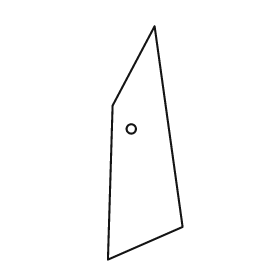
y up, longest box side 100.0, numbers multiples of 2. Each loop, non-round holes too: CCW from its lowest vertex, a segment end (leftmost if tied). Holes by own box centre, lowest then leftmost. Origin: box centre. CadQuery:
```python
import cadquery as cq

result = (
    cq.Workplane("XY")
    .moveTo(-16.0, -50.0)
    .lineTo(16.0, -36.0)
    .lineTo(4.0, 50.0)
    .lineTo(-14.0, 16.0)
    .close()
    .moveTo(-6.0, 6.0)
    .circle(2.0)
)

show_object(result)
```